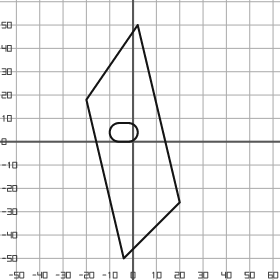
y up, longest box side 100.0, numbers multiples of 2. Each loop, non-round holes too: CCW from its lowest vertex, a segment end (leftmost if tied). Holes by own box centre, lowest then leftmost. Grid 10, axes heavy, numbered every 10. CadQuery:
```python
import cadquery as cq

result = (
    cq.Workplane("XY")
    .moveTo(-4.0, -50.0)
    .lineTo(20.0, -26.0)
    .lineTo(2.0, 50.0)
    .lineTo(-20.0, 18.0)
    .close()
    .moveTo(-6.0, 0.0)
    .lineTo(-2.0, 0.0)
    .threePointArc((2.0, 4.0), (-2.0, 8.0))
    .lineTo(-6.0, 8.0)
    .threePointArc((-10.0, 4.0), (-6.0, 0.0))
    .close()
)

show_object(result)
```